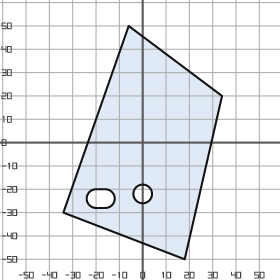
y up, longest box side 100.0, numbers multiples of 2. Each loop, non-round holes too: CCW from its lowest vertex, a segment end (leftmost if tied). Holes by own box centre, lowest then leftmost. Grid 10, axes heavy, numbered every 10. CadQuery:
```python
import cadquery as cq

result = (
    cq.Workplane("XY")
    .moveTo(18.0, -50.0)
    .lineTo(34.0, 20.0)
    .lineTo(-6.0, 50.0)
    .lineTo(-34.0, -30.0)
    .close()
    .moveTo(-20.0, -28.0)
    .lineTo(-16.0, -28.0)
    .threePointArc((-12.0, -24.0), (-16.0, -20.0))
    .lineTo(-20.0, -20.0)
    .threePointArc((-24.0, -24.0), (-20.0, -28.0))
    .close()
    .moveTo(0.0, -22.0)
    .circle(4.0)
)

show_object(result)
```